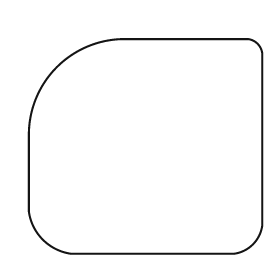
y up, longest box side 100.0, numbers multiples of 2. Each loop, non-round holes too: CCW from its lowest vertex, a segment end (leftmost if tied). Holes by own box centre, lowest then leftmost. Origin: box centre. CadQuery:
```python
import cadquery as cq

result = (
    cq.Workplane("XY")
    .moveTo(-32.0, -46.0)
    .lineTo(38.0, -46.0)
    .threePointArc((46.0, -42.0), (50.0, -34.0))
    .lineTo(50.0, 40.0)
    .threePointArc((48.0, 44.0), (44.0, 46.0))
    .lineTo(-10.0, 46.0)
    .threePointArc((-38.0, 34.0), (-50.0, 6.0))
    .lineTo(-50.0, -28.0)
    .threePointArc((-44.0, -40.0), (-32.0, -46.0))
    .close()
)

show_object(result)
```